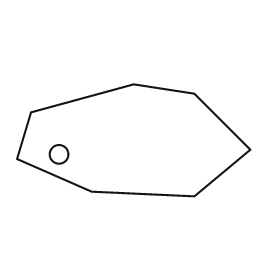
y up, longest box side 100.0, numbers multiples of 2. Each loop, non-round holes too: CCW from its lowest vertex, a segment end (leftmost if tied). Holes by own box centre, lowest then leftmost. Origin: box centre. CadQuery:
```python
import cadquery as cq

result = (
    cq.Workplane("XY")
    .moveTo(26.0, -24.0)
    .lineTo(50.0, -4.0)
    .lineTo(26.0, 20.0)
    .lineTo(0.0, 24.0)
    .lineTo(-44.0, 12.0)
    .lineTo(-50.0, -8.0)
    .lineTo(-18.0, -22.0)
    .close()
    .moveTo(-32.0, -6.0)
    .circle(4.0)
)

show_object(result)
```